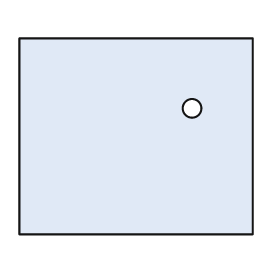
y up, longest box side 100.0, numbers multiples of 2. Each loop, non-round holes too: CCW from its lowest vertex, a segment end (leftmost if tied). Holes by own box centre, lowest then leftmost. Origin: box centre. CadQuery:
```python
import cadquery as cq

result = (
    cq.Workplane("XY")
    .moveTo(-50.0, -42.0)
    .lineTo(50.0, -42.0)
    .lineTo(50.0, 42.0)
    .lineTo(-50.0, 42.0)
    .close()
    .moveTo(24.0, 12.0)
    .circle(4.0)
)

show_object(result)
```